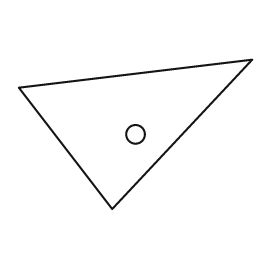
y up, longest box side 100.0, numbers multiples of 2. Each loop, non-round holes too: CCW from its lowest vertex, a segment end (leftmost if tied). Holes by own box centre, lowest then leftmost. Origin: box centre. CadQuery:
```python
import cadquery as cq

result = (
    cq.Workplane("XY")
    .moveTo(-10.0, -32.0)
    .lineTo(50.0, 32.0)
    .lineTo(-50.0, 20.0)
    .close()
    .moveTo(0.0, 0.0)
    .circle(4.0)
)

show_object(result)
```